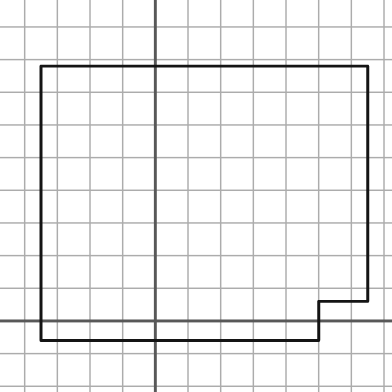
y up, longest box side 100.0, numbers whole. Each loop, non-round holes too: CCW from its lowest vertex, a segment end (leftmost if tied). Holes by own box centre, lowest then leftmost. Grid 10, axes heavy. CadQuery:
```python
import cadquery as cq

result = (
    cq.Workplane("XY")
    .moveTo(-35.0, -6.0)
    .lineTo(50.0, -6.0)
    .lineTo(50.0, 6.0)
    .lineTo(65.0, 6.0)
    .lineTo(65.0, 78.0)
    .lineTo(-35.0, 78.0)
    .close()
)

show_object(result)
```